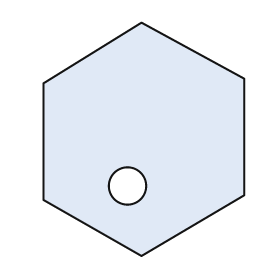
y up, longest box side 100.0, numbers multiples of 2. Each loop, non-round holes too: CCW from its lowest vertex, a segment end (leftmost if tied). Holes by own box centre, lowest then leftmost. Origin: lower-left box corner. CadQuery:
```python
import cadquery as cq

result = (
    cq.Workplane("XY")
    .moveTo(42.0, 0.0)
    .lineTo(86.0, 26.0)
    .lineTo(86.0, 76.0)
    .lineTo(42.0, 100.0)
    .lineTo(0.0, 74.0)
    .lineTo(0.0, 24.0)
    .close()
    .moveTo(36.0, 30.0)
    .circle(8.0)
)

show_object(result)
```